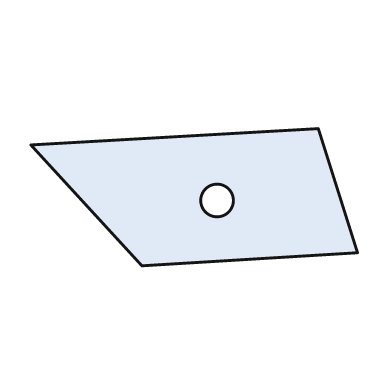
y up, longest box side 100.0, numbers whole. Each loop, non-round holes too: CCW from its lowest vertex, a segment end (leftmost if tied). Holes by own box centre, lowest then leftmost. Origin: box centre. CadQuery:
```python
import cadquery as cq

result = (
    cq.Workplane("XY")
    .moveTo(-16.0, -21.0)
    .lineTo(50.0, -17.0)
    .lineTo(38.0, 21.0)
    .lineTo(-50.0, 16.0)
    .close()
    .moveTo(7.0, -1.0)
    .circle(5.0)
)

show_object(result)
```